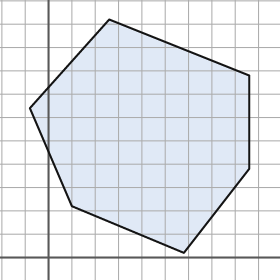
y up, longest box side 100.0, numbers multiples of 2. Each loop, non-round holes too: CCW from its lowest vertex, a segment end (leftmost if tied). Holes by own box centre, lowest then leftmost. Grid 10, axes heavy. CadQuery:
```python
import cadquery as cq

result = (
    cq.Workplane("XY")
    .moveTo(58.0, 2.0)
    .lineTo(86.0, 38.0)
    .lineTo(86.0, 78.0)
    .lineTo(26.0, 102.0)
    .lineTo(-8.0, 64.0)
    .lineTo(10.0, 22.0)
    .close()
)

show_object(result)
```